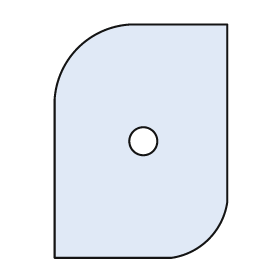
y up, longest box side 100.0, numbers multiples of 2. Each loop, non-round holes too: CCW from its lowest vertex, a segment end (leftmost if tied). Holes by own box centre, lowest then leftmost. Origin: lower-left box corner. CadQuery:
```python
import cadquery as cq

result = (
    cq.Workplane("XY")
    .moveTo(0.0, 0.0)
    .lineTo(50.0, 0.0)
    .threePointArc((66.0, 8.0), (74.0, 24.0))
    .lineTo(74.0, 100.0)
    .lineTo(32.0, 100.0)
    .threePointArc((10.0, 90.0), (0.0, 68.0))
    .close()
    .moveTo(38.0, 50.0)
    .circle(6.0)
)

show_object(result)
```